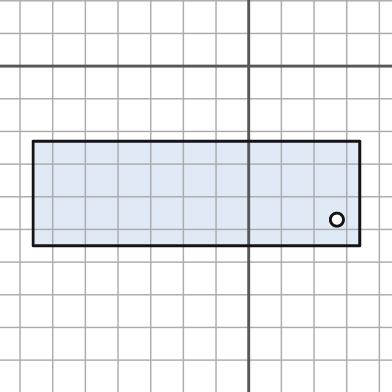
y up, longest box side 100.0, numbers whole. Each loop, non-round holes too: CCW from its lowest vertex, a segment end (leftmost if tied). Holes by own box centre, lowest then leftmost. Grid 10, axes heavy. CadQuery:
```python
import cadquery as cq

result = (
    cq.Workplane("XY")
    .moveTo(-66.0, -55.0)
    .lineTo(34.0, -55.0)
    .lineTo(34.0, -23.0)
    .lineTo(-66.0, -23.0)
    .close()
    .moveTo(27.0, -47.0)
    .circle(2.0)
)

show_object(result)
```